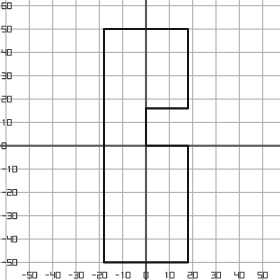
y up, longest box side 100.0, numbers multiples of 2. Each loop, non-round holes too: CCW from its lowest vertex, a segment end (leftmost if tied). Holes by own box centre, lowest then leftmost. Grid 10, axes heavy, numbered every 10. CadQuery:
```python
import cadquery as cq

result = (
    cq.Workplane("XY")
    .moveTo(-18.0, -50.0)
    .lineTo(18.0, -50.0)
    .lineTo(18.0, 0.0)
    .lineTo(0.0, 0.0)
    .lineTo(0.0, 16.0)
    .lineTo(18.0, 16.0)
    .lineTo(18.0, 50.0)
    .lineTo(-18.0, 50.0)
    .close()
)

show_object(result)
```